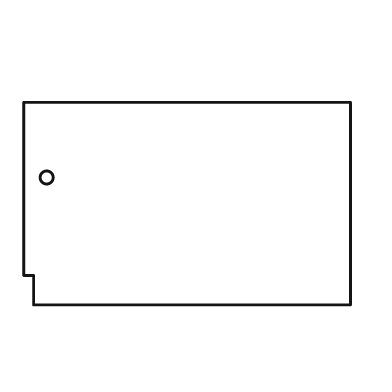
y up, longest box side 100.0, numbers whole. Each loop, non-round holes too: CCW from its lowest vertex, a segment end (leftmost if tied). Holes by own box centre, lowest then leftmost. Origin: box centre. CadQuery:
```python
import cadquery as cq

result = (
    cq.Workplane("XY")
    .moveTo(-47.0, -31.0)
    .lineTo(50.0, -31.0)
    .lineTo(50.0, 31.0)
    .lineTo(-50.0, 31.0)
    .lineTo(-50.0, -22.0)
    .lineTo(-47.0, -22.0)
    .close()
    .moveTo(-43.0, 8.0)
    .circle(2.0)
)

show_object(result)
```